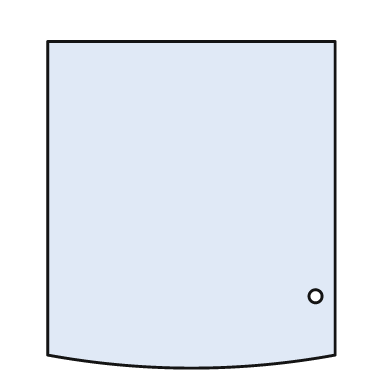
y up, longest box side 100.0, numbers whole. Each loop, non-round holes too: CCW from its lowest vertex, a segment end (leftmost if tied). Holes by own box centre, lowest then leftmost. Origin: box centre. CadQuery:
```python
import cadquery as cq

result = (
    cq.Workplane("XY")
    .moveTo(-44.0, -46.0)
    .threePointArc((0.0, -50.0), (44.0, -46.0))
    .lineTo(44.0, 50.0)
    .lineTo(-44.0, 50.0)
    .close()
    .moveTo(38.0, -28.0)
    .circle(2.0)
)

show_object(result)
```